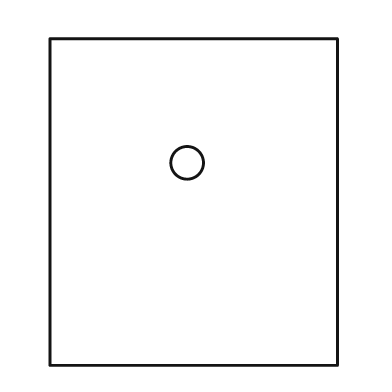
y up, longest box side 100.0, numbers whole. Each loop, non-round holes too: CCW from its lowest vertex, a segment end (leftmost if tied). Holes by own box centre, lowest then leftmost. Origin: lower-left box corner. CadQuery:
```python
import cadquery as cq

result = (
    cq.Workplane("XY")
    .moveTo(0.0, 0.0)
    .lineTo(88.0, 0.0)
    .lineTo(88.0, 100.0)
    .lineTo(0.0, 100.0)
    .close()
    .moveTo(42.0, 62.0)
    .circle(5.0)
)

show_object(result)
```